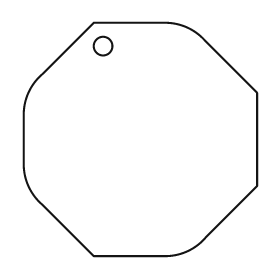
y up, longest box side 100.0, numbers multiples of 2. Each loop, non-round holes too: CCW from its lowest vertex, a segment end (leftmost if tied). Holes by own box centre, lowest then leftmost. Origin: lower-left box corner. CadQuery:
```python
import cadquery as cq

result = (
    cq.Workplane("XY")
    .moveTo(30.0, 0.0)
    .lineTo(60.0, 0.0)
    .threePointArc((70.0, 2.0), (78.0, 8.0))
    .lineTo(100.0, 30.0)
    .lineTo(100.0, 70.0)
    .lineTo(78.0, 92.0)
    .threePointArc((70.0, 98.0), (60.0, 100.0))
    .lineTo(30.0, 100.0)
    .lineTo(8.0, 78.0)
    .threePointArc((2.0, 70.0), (0.0, 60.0))
    .lineTo(0.0, 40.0)
    .threePointArc((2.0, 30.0), (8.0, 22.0))
    .close()
    .moveTo(34.0, 90.0)
    .circle(4.0)
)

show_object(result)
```